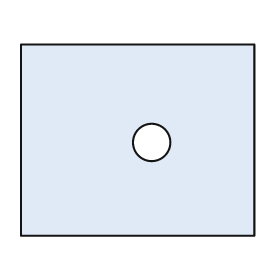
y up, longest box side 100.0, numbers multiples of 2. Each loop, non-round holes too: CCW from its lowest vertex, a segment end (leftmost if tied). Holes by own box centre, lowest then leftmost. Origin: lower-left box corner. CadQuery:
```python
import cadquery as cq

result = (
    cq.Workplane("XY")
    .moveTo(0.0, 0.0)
    .lineTo(100.0, 0.0)
    .lineTo(100.0, 82.0)
    .lineTo(0.0, 82.0)
    .close()
    .moveTo(56.0, 40.0)
    .circle(8.0)
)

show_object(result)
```